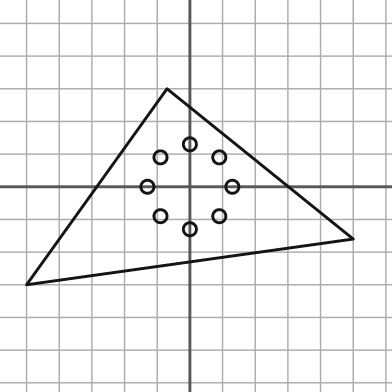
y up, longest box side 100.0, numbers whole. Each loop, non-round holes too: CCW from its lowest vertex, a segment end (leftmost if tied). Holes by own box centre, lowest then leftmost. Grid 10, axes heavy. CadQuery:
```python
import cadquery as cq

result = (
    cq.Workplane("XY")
    .moveTo(-50.0, -30.0)
    .lineTo(50.0, -16.0)
    .lineTo(-7.0, 30.0)
    .close()
    .moveTo(0.0, -13.0)
    .circle(2.0)
    .moveTo(-9.0, -9.0)
    .circle(2.0)
    .moveTo(9.0, -9.0)
    .circle(2.0)
    .moveTo(-13.0, 0.0)
    .circle(2.0)
    .moveTo(13.0, 0.0)
    .circle(2.0)
    .moveTo(-9.0, 9.0)
    .circle(2.0)
    .moveTo(9.0, 9.0)
    .circle(2.0)
    .moveTo(0.0, 13.0)
    .circle(2.0)
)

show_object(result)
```